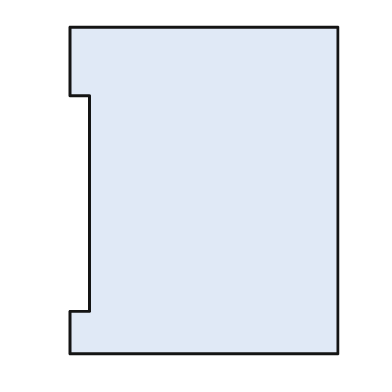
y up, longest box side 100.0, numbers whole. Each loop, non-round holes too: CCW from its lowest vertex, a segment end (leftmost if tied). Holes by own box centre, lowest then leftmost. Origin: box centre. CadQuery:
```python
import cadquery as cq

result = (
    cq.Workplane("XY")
    .moveTo(-41.0, -50.0)
    .lineTo(41.0, -50.0)
    .lineTo(41.0, 50.0)
    .lineTo(-41.0, 50.0)
    .lineTo(-41.0, 29.0)
    .lineTo(-35.0, 29.0)
    .lineTo(-35.0, -37.0)
    .lineTo(-41.0, -37.0)
    .close()
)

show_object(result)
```